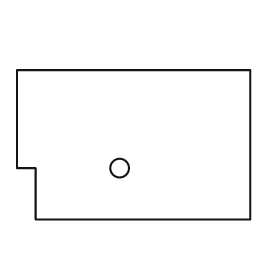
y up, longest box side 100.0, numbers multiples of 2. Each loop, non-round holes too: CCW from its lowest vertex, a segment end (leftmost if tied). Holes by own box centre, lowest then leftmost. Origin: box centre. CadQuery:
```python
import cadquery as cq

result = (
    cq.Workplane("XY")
    .moveTo(-42.0, -32.0)
    .lineTo(50.0, -32.0)
    .lineTo(50.0, 32.0)
    .lineTo(-50.0, 32.0)
    .lineTo(-50.0, -10.0)
    .lineTo(-42.0, -10.0)
    .close()
    .moveTo(-6.0, -10.0)
    .circle(4.0)
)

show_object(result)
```